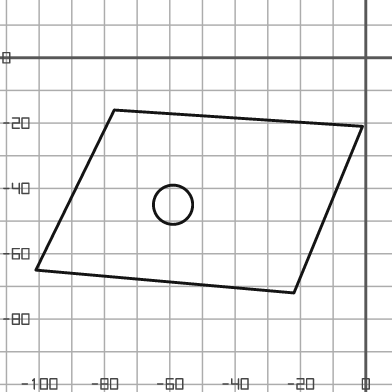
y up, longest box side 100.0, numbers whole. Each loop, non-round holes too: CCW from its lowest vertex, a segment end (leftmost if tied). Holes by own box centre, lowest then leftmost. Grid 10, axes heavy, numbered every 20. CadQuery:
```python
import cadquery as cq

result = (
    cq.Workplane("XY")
    .moveTo(-22.0, -72.0)
    .lineTo(-1.0, -21.0)
    .lineTo(-77.0, -16.0)
    .lineTo(-101.0, -65.0)
    .close()
    .moveTo(-59.0, -45.0)
    .circle(6.0)
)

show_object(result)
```